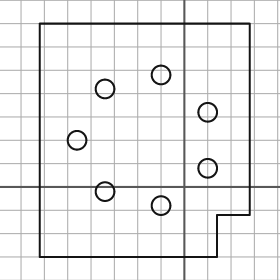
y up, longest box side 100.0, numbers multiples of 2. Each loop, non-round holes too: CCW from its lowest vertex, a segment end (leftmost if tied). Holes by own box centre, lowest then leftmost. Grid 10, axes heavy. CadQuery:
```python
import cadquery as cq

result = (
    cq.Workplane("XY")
    .moveTo(-62.0, -30.0)
    .lineTo(14.0, -30.0)
    .lineTo(14.0, -12.0)
    .lineTo(28.0, -12.0)
    .lineTo(28.0, 70.0)
    .lineTo(-62.0, 70.0)
    .close()
    .moveTo(-10.0, -8.0)
    .circle(4.0)
    .moveTo(-34.0, -2.0)
    .circle(4.0)
    .moveTo(10.0, 8.0)
    .circle(4.0)
    .moveTo(-46.0, 20.0)
    .circle(4.0)
    .moveTo(10.0, 32.0)
    .circle(4.0)
    .moveTo(-34.0, 42.0)
    .circle(4.0)
    .moveTo(-10.0, 48.0)
    .circle(4.0)
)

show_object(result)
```